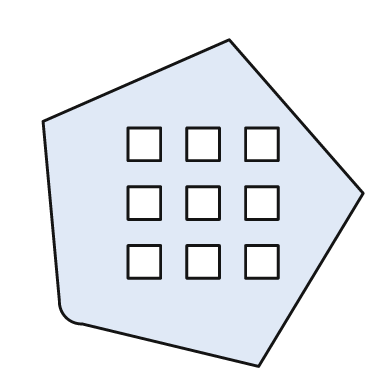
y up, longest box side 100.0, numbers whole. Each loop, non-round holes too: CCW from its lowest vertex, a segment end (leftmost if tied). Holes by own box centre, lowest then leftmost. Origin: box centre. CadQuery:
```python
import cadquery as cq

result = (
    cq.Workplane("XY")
    .moveTo(17.0, -50.0)
    .lineTo(49.0, 3.0)
    .lineTo(8.0, 50.0)
    .lineTo(-49.0, 25.0)
    .lineTo(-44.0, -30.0)
    .threePointArc((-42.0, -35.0), (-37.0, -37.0))
    .close()
    .moveTo(-23.0, -23.0)
    .lineTo(-13.0, -23.0)
    .lineTo(-13.0, -13.0)
    .lineTo(-23.0, -13.0)
    .close()
    .moveTo(-5.0, -23.0)
    .lineTo(5.0, -23.0)
    .lineTo(5.0, -13.0)
    .lineTo(-5.0, -13.0)
    .close()
    .moveTo(13.0, -23.0)
    .lineTo(23.0, -23.0)
    .lineTo(23.0, -13.0)
    .lineTo(13.0, -13.0)
    .close()
    .moveTo(-23.0, -5.0)
    .lineTo(-13.0, -5.0)
    .lineTo(-13.0, 5.0)
    .lineTo(-23.0, 5.0)
    .close()
    .moveTo(-5.0, -5.0)
    .lineTo(5.0, -5.0)
    .lineTo(5.0, 5.0)
    .lineTo(-5.0, 5.0)
    .close()
    .moveTo(13.0, -5.0)
    .lineTo(23.0, -5.0)
    .lineTo(23.0, 5.0)
    .lineTo(13.0, 5.0)
    .close()
    .moveTo(-23.0, 13.0)
    .lineTo(-13.0, 13.0)
    .lineTo(-13.0, 23.0)
    .lineTo(-23.0, 23.0)
    .close()
    .moveTo(-5.0, 13.0)
    .lineTo(5.0, 13.0)
    .lineTo(5.0, 23.0)
    .lineTo(-5.0, 23.0)
    .close()
    .moveTo(13.0, 13.0)
    .lineTo(23.0, 13.0)
    .lineTo(23.0, 23.0)
    .lineTo(13.0, 23.0)
    .close()
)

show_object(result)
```